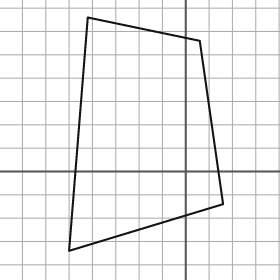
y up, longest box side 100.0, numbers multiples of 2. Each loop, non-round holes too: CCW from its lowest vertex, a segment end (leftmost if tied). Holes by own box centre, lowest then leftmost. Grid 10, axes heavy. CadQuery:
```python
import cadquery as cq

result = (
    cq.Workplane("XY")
    .moveTo(-50.0, -34.0)
    .lineTo(16.0, -14.0)
    .lineTo(6.0, 56.0)
    .lineTo(-42.0, 66.0)
    .close()
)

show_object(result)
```